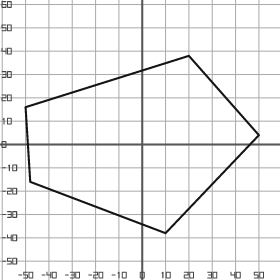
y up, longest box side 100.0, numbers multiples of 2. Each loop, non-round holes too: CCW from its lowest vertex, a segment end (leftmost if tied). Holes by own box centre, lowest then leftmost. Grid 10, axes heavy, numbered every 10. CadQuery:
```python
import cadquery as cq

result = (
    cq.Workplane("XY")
    .moveTo(10.0, -38.0)
    .lineTo(50.0, 4.0)
    .lineTo(20.0, 38.0)
    .lineTo(-50.0, 16.0)
    .lineTo(-48.0, -16.0)
    .close()
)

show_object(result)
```